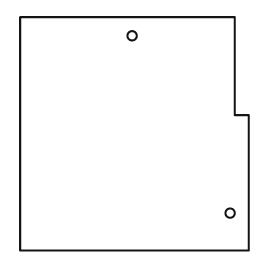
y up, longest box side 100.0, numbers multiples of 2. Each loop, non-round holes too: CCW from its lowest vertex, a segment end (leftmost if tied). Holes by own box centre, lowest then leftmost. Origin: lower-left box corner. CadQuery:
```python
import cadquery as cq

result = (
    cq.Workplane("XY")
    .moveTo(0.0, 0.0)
    .lineTo(98.0, 0.0)
    .lineTo(98.0, 58.0)
    .lineTo(92.0, 58.0)
    .lineTo(92.0, 100.0)
    .lineTo(0.0, 100.0)
    .close()
    .moveTo(90.0, 16.0)
    .circle(2.0)
    .moveTo(48.0, 92.0)
    .circle(2.0)
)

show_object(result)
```